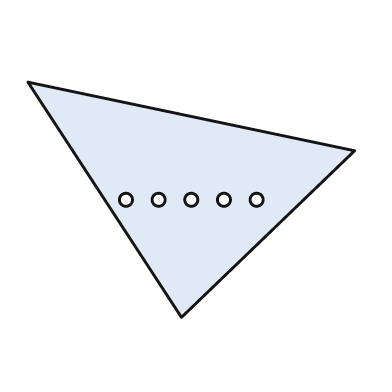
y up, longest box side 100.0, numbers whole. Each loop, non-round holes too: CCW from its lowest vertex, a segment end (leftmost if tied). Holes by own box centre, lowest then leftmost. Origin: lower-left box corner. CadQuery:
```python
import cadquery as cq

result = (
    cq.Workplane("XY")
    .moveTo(47.0, 0.0)
    .lineTo(100.0, 51.0)
    .lineTo(0.0, 72.0)
    .close()
    .moveTo(30.0, 36.0)
    .circle(2.0)
    .moveTo(40.0, 36.0)
    .circle(2.0)
    .moveTo(50.0, 36.0)
    .circle(2.0)
    .moveTo(60.0, 36.0)
    .circle(2.0)
    .moveTo(70.0, 36.0)
    .circle(2.0)
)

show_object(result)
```